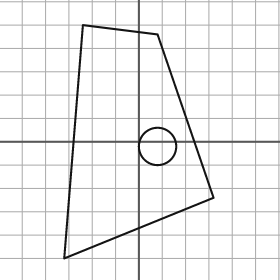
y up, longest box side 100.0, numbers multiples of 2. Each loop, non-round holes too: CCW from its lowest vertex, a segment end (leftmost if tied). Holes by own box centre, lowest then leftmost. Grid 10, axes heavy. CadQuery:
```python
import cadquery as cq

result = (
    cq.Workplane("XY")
    .moveTo(-32.0, -50.0)
    .lineTo(32.0, -24.0)
    .lineTo(8.0, 46.0)
    .lineTo(-24.0, 50.0)
    .close()
    .moveTo(8.0, -2.0)
    .circle(8.0)
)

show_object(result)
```